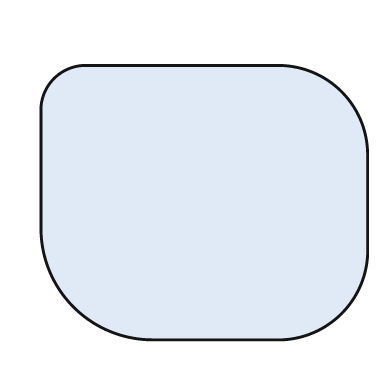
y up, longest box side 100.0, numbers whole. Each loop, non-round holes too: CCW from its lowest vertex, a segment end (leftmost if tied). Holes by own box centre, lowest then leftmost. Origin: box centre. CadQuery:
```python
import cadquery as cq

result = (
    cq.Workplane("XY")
    .moveTo(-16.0, -42.0)
    .lineTo(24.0, -42.0)
    .threePointArc((42.0, -34.0), (50.0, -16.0))
    .lineTo(50.0, 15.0)
    .threePointArc((42.0, 34.0), (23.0, 42.0))
    .lineTo(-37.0, 42.0)
    .threePointArc((-46.0, 38.0), (-50.0, 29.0))
    .lineTo(-50.0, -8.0)
    .threePointArc((-40.0, -32.0), (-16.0, -42.0))
    .close()
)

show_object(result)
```